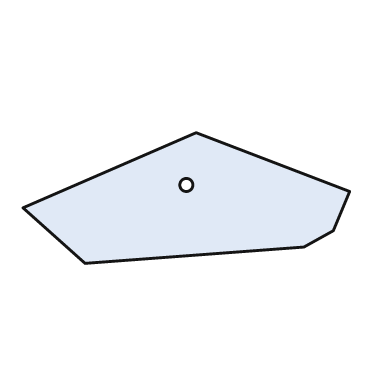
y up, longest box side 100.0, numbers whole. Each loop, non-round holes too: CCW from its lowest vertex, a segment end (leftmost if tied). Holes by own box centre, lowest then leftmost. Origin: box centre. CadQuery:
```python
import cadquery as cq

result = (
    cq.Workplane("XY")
    .moveTo(-31.0, -20.0)
    .lineTo(36.0, -15.0)
    .lineTo(45.0, -10.0)
    .lineTo(50.0, 2.0)
    .lineTo(3.0, 20.0)
    .lineTo(-50.0, -3.0)
    .close()
    .moveTo(0.0, 4.0)
    .circle(2.0)
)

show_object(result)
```